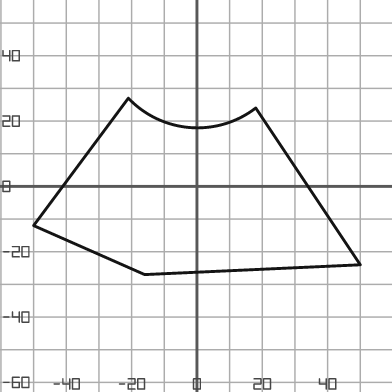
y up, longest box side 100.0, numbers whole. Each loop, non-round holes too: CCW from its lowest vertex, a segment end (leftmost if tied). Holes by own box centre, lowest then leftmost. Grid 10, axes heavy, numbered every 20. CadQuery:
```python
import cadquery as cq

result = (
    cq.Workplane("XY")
    .moveTo(-16.0, -27.0)
    .lineTo(50.0, -24.0)
    .lineTo(18.0, 24.0)
    .threePointArc((-2.0, 18.0), (-21.0, 27.0))
    .lineTo(-50.0, -12.0)
    .close()
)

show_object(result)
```